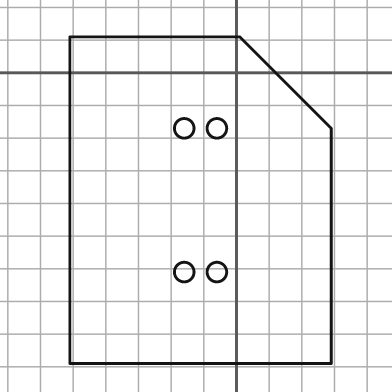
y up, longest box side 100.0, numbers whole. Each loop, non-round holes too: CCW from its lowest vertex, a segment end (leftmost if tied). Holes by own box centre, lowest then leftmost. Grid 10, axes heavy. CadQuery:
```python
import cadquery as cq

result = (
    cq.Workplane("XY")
    .moveTo(-51.0, -89.0)
    .lineTo(29.0, -89.0)
    .lineTo(29.0, -17.0)
    .lineTo(1.0, 11.0)
    .lineTo(-51.0, 11.0)
    .close()
    .moveTo(-16.0, -61.0)
    .circle(3.0)
    .moveTo(-6.0, -61.0)
    .circle(3.0)
    .moveTo(-16.0, -17.0)
    .circle(3.0)
    .moveTo(-6.0, -17.0)
    .circle(3.0)
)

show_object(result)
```